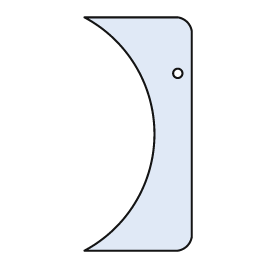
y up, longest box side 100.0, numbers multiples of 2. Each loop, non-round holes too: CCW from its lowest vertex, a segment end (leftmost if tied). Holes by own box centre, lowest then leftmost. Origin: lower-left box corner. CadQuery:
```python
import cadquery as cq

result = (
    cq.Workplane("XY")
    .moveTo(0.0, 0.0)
    .lineTo(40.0, 0.0)
    .threePointArc((44.0, 2.0), (46.0, 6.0))
    .lineTo(46.0, 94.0)
    .threePointArc((44.0, 98.0), (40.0, 100.0))
    .lineTo(0.0, 100.0)
    .threePointArc((30.0, 50.0), (0.0, 0.0))
    .close()
    .moveTo(40.0, 76.0)
    .circle(2.0)
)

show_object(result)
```